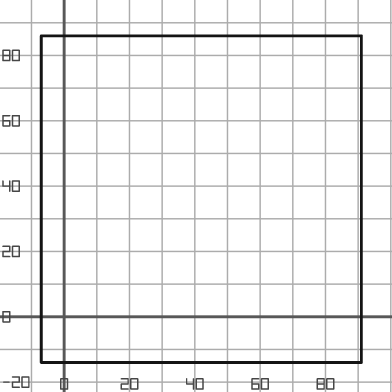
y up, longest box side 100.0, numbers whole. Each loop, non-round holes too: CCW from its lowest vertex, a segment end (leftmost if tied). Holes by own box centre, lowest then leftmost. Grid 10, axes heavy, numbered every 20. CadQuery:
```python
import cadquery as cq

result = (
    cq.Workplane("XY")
    .moveTo(-7.0, -14.0)
    .lineTo(91.0, -14.0)
    .lineTo(91.0, 86.0)
    .lineTo(-7.0, 86.0)
    .close()
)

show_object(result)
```